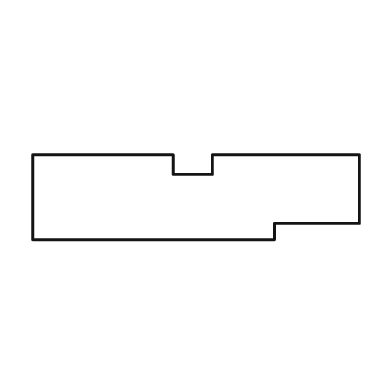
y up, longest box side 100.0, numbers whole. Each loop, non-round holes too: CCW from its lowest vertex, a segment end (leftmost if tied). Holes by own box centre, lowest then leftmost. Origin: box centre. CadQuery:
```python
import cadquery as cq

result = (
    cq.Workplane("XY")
    .moveTo(-50.0, -13.0)
    .lineTo(24.0, -13.0)
    .lineTo(24.0, -8.0)
    .lineTo(50.0, -8.0)
    .lineTo(50.0, 13.0)
    .lineTo(5.0, 13.0)
    .lineTo(5.0, 7.0)
    .lineTo(-7.0, 7.0)
    .lineTo(-7.0, 13.0)
    .lineTo(-50.0, 13.0)
    .close()
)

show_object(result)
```